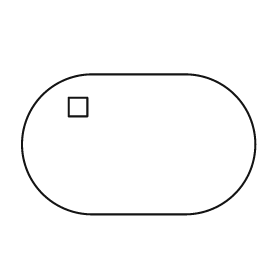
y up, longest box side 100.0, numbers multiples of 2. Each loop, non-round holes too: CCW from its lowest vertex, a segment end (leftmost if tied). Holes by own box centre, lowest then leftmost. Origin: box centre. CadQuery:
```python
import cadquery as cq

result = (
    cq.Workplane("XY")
    .moveTo(-20.0, -30.0)
    .lineTo(20.0, -30.0)
    .threePointArc((50.0, 0.0), (20.0, 30.0))
    .lineTo(-20.0, 30.0)
    .threePointArc((-50.0, 0.0), (-20.0, -30.0))
    .close()
    .moveTo(-30.0, 12.0)
    .lineTo(-22.0, 12.0)
    .lineTo(-22.0, 20.0)
    .lineTo(-30.0, 20.0)
    .close()
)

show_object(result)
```